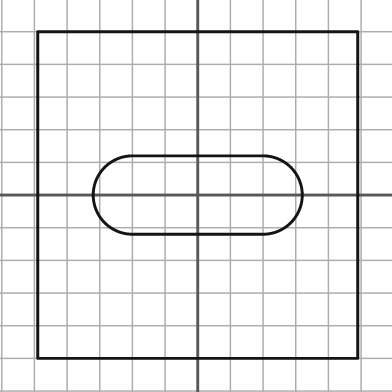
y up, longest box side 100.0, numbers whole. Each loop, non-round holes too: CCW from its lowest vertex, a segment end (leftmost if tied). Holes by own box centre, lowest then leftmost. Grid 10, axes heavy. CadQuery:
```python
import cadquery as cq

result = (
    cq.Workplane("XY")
    .moveTo(-49.0, -50.0)
    .lineTo(49.0, -50.0)
    .lineTo(49.0, 50.0)
    .lineTo(-49.0, 50.0)
    .close()
    .moveTo(-20.0, -12.0)
    .lineTo(20.0, -12.0)
    .threePointArc((32.0, 0.0), (20.0, 12.0))
    .lineTo(-20.0, 12.0)
    .threePointArc((-32.0, 0.0), (-20.0, -12.0))
    .close()
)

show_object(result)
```